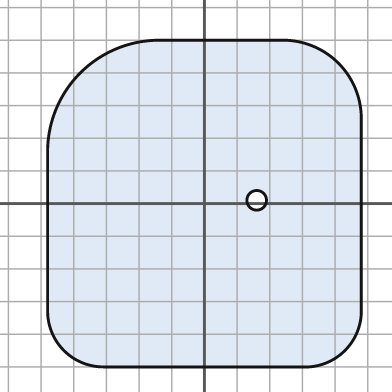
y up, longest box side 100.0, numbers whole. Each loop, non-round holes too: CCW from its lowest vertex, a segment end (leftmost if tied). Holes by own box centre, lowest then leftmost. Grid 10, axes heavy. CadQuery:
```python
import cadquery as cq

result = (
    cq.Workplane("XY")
    .moveTo(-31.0, -50.0)
    .lineTo(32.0, -50.0)
    .threePointArc((43.0, -45.0), (48.0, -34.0))
    .lineTo(48.0, 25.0)
    .threePointArc((41.0, 43.0), (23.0, 50.0))
    .lineTo(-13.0, 50.0)
    .threePointArc((-38.0, 40.0), (-48.0, 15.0))
    .lineTo(-48.0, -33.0)
    .threePointArc((-43.0, -45.0), (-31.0, -50.0))
    .close()
    .moveTo(16.0, 1.0)
    .circle(3.0)
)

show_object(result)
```